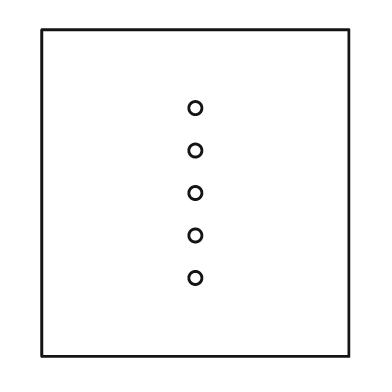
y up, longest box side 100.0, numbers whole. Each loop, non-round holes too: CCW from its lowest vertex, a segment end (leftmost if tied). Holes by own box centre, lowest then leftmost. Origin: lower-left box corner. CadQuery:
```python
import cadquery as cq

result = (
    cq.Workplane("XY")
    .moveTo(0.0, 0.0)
    .lineTo(94.0, 0.0)
    .lineTo(94.0, 100.0)
    .lineTo(0.0, 100.0)
    .close()
    .moveTo(47.0, 24.0)
    .circle(2.0)
    .moveTo(47.0, 37.0)
    .circle(2.0)
    .moveTo(47.0, 50.0)
    .circle(2.0)
    .moveTo(47.0, 63.0)
    .circle(2.0)
    .moveTo(47.0, 76.0)
    .circle(2.0)
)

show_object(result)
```